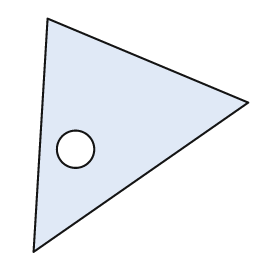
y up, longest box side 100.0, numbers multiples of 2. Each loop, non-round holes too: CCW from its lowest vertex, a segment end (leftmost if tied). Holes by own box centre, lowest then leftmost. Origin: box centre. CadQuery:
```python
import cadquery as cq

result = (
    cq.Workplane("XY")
    .moveTo(-46.0, -50.0)
    .lineTo(46.0, 14.0)
    .lineTo(-40.0, 50.0)
    .close()
    .moveTo(-28.0, -6.0)
    .circle(8.0)
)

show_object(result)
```